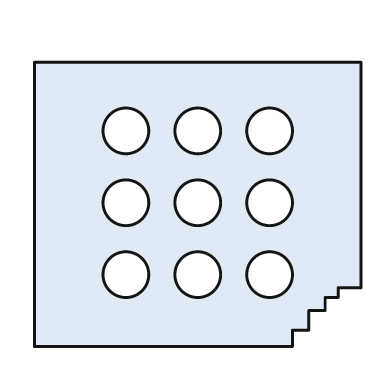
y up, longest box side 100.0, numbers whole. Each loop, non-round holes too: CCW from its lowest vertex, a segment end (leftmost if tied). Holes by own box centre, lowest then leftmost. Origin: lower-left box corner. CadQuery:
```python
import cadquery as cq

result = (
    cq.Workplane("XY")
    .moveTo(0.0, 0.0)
    .lineTo(79.0, 0.0)
    .lineTo(79.0, 5.0)
    .lineTo(84.0, 5.0)
    .lineTo(84.0, 11.0)
    .lineTo(89.0, 11.0)
    .lineTo(89.0, 15.0)
    .lineTo(93.0, 15.0)
    .lineTo(93.0, 18.0)
    .lineTo(100.0, 18.0)
    .lineTo(100.0, 87.0)
    .lineTo(0.0, 87.0)
    .close()
    .moveTo(28.0, 22.0)
    .circle(7.0)
    .moveTo(50.0, 22.0)
    .circle(7.0)
    .moveTo(72.0, 22.0)
    .circle(7.0)
    .moveTo(28.0, 44.0)
    .circle(7.0)
    .moveTo(50.0, 44.0)
    .circle(7.0)
    .moveTo(72.0, 44.0)
    .circle(7.0)
    .moveTo(28.0, 66.0)
    .circle(7.0)
    .moveTo(50.0, 66.0)
    .circle(7.0)
    .moveTo(72.0, 66.0)
    .circle(7.0)
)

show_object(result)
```